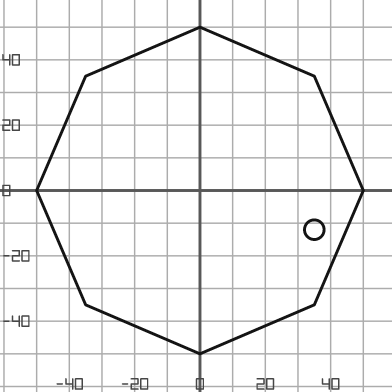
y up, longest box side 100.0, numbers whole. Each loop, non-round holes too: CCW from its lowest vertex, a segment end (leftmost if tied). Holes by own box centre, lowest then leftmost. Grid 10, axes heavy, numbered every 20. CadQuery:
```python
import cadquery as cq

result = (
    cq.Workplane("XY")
    .moveTo(0.0, -50.0)
    .lineTo(35.0, -35.0)
    .lineTo(50.0, 0.0)
    .lineTo(35.0, 35.0)
    .lineTo(0.0, 50.0)
    .lineTo(-35.0, 35.0)
    .lineTo(-50.0, 0.0)
    .lineTo(-35.0, -35.0)
    .close()
    .moveTo(35.0, -12.0)
    .circle(3.0)
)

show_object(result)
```